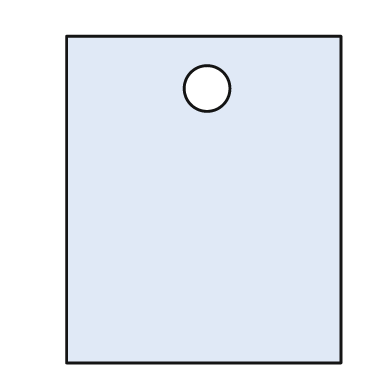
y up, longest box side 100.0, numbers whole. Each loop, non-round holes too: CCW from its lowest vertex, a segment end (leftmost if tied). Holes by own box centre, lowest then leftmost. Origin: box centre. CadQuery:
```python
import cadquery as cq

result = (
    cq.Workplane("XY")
    .moveTo(-42.0, -50.0)
    .lineTo(42.0, -50.0)
    .lineTo(42.0, 50.0)
    .lineTo(-42.0, 50.0)
    .close()
    .moveTo(1.0, 34.0)
    .circle(7.0)
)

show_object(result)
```